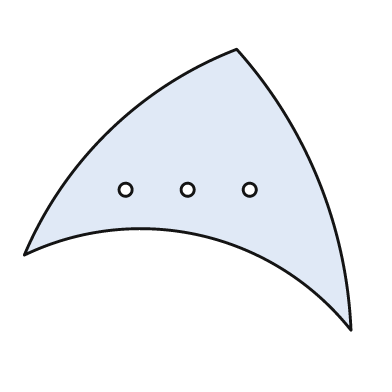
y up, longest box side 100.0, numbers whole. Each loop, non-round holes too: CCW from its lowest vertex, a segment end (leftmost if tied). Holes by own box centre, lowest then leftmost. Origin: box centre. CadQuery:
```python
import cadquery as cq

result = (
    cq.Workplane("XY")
    .moveTo(50.0, -43.0)
    .threePointArc((40.0, 3.0), (15.0, 43.0))
    .threePointArc((-24.0, 18.0), (-50.0, -20.0))
    .threePointArc((4.0, -14.0), (50.0, -43.0))
    .close()
    .moveTo(-19.0, 0.0)
    .circle(2.0)
    .moveTo(0.0, 0.0)
    .circle(2.0)
    .moveTo(19.0, 0.0)
    .circle(2.0)
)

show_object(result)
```